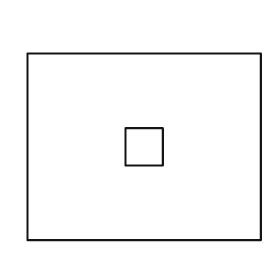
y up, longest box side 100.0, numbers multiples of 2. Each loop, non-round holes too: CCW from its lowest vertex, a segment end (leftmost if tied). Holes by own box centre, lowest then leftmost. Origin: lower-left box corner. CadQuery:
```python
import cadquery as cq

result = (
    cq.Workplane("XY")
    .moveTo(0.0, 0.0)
    .lineTo(100.0, 0.0)
    .lineTo(100.0, 80.0)
    .lineTo(0.0, 80.0)
    .close()
    .moveTo(42.0, 32.0)
    .lineTo(58.0, 32.0)
    .lineTo(58.0, 48.0)
    .lineTo(42.0, 48.0)
    .close()
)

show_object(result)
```